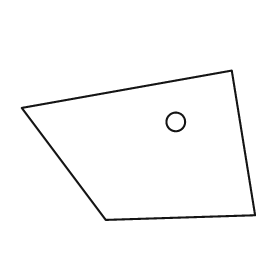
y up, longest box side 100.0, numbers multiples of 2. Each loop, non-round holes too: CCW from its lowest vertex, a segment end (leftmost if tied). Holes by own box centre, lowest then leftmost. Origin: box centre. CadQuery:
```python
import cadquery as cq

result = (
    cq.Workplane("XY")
    .moveTo(-14.0, -32.0)
    .lineTo(50.0, -30.0)
    .lineTo(40.0, 32.0)
    .lineTo(-50.0, 16.0)
    .close()
    .moveTo(16.0, 10.0)
    .circle(4.0)
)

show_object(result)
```